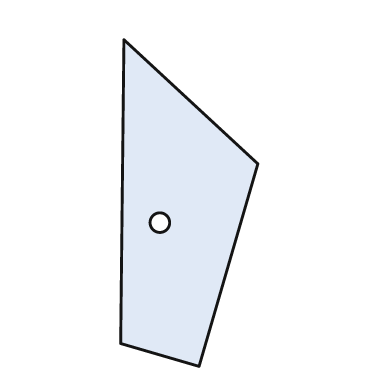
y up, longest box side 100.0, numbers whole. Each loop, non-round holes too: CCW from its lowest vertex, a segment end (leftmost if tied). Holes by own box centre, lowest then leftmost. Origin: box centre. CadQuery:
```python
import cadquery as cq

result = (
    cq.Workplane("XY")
    .moveTo(3.0, -50.0)
    .lineTo(21.0, 12.0)
    .lineTo(-20.0, 50.0)
    .lineTo(-21.0, -43.0)
    .close()
    .moveTo(-9.0, -6.0)
    .circle(3.0)
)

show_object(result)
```